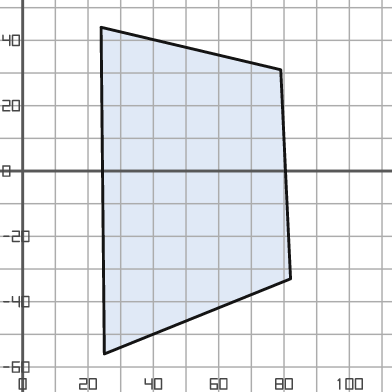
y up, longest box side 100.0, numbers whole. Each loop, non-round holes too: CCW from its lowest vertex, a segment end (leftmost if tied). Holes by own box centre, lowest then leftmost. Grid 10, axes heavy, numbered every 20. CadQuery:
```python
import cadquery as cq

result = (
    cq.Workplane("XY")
    .moveTo(25.0, -56.0)
    .lineTo(82.0, -33.0)
    .lineTo(79.0, 31.0)
    .lineTo(24.0, 44.0)
    .close()
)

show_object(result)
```